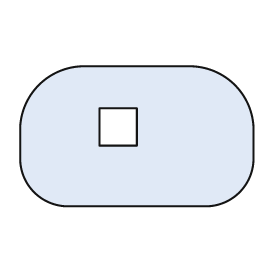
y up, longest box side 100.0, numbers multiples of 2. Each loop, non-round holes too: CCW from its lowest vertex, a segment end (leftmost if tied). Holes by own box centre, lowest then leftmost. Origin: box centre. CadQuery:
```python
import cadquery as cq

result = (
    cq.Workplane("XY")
    .moveTo(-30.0, -30.0)
    .lineTo(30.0, -30.0)
    .threePointArc((44.0, -24.0), (50.0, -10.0))
    .lineTo(50.0, 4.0)
    .threePointArc((42.0, 22.0), (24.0, 30.0))
    .lineTo(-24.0, 30.0)
    .threePointArc((-42.0, 22.0), (-50.0, 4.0))
    .lineTo(-50.0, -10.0)
    .threePointArc((-44.0, -24.0), (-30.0, -30.0))
    .close()
    .moveTo(-16.0, -4.0)
    .lineTo(0.0, -4.0)
    .lineTo(0.0, 12.0)
    .lineTo(-16.0, 12.0)
    .close()
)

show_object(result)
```